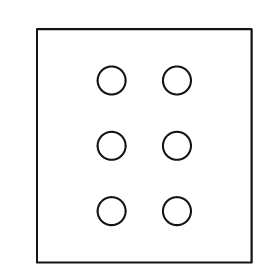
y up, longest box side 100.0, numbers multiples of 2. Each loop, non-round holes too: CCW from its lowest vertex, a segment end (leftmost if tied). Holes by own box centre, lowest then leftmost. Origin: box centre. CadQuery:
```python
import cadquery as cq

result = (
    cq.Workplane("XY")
    .moveTo(-46.0, -50.0)
    .lineTo(46.0, -50.0)
    .lineTo(46.0, 50.0)
    .lineTo(-46.0, 50.0)
    .close()
    .moveTo(-14.0, -28.0)
    .circle(6.0)
    .moveTo(14.0, -28.0)
    .circle(6.0)
    .moveTo(-14.0, 0.0)
    .circle(6.0)
    .moveTo(14.0, 0.0)
    .circle(6.0)
    .moveTo(-14.0, 28.0)
    .circle(6.0)
    .moveTo(14.0, 28.0)
    .circle(6.0)
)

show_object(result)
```